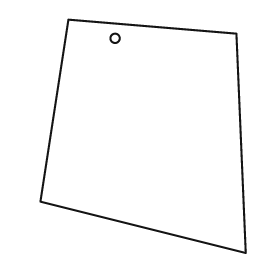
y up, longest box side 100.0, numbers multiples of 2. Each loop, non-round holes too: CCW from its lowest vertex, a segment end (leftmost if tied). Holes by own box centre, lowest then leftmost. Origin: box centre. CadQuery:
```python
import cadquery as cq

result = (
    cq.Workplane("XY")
    .moveTo(44.0, -50.0)
    .lineTo(40.0, 44.0)
    .lineTo(-32.0, 50.0)
    .lineTo(-44.0, -28.0)
    .close()
    .moveTo(-12.0, 42.0)
    .circle(2.0)
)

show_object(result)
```